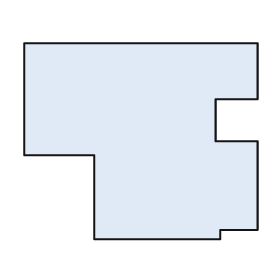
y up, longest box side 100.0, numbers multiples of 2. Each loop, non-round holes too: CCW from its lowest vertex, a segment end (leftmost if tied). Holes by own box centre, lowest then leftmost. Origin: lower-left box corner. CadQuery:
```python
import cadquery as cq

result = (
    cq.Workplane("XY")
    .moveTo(30.0, 0.0)
    .lineTo(84.0, 0.0)
    .lineTo(84.0, 4.0)
    .lineTo(100.0, 4.0)
    .lineTo(100.0, 42.0)
    .lineTo(82.0, 42.0)
    .lineTo(82.0, 60.0)
    .lineTo(100.0, 60.0)
    .lineTo(100.0, 84.0)
    .lineTo(0.0, 84.0)
    .lineTo(0.0, 36.0)
    .lineTo(30.0, 36.0)
    .close()
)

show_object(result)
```